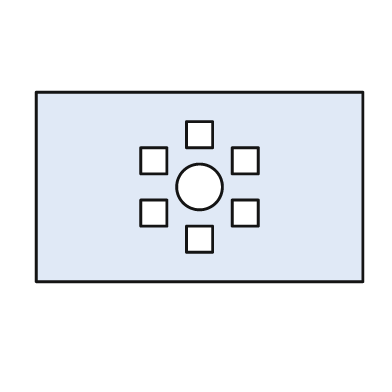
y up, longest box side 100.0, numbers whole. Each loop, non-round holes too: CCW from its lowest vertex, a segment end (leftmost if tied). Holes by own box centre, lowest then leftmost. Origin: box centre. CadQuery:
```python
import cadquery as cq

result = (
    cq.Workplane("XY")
    .moveTo(-50.0, -29.0)
    .lineTo(50.0, -29.0)
    .lineTo(50.0, 29.0)
    .lineTo(-50.0, 29.0)
    .close()
    .moveTo(-4.0, -20.0)
    .lineTo(4.0, -20.0)
    .lineTo(4.0, -12.0)
    .lineTo(-4.0, -12.0)
    .close()
    .moveTo(-18.0, -12.0)
    .lineTo(-10.0, -12.0)
    .lineTo(-10.0, -4.0)
    .lineTo(-18.0, -4.0)
    .close()
    .moveTo(10.0, -12.0)
    .lineTo(18.0, -12.0)
    .lineTo(18.0, -4.0)
    .lineTo(10.0, -4.0)
    .close()
    .moveTo(0.0, 0.0)
    .circle(7.0)
    .moveTo(-18.0, 4.0)
    .lineTo(-10.0, 4.0)
    .lineTo(-10.0, 12.0)
    .lineTo(-18.0, 12.0)
    .close()
    .moveTo(10.0, 4.0)
    .lineTo(18.0, 4.0)
    .lineTo(18.0, 12.0)
    .lineTo(10.0, 12.0)
    .close()
    .moveTo(-4.0, 12.0)
    .lineTo(4.0, 12.0)
    .lineTo(4.0, 20.0)
    .lineTo(-4.0, 20.0)
    .close()
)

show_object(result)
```